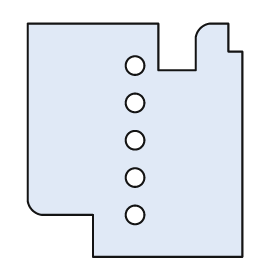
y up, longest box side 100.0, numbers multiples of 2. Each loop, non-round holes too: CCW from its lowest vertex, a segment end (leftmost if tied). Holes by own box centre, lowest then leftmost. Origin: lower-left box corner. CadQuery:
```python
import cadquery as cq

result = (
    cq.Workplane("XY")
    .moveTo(28.0, 0.0)
    .lineTo(92.0, 0.0)
    .lineTo(92.0, 88.0)
    .lineTo(86.0, 88.0)
    .lineTo(86.0, 100.0)
    .lineTo(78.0, 100.0)
    .threePointArc((74.0, 98.0), (72.0, 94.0))
    .lineTo(72.0, 80.0)
    .lineTo(56.0, 80.0)
    .lineTo(56.0, 100.0)
    .lineTo(0.0, 100.0)
    .lineTo(0.0, 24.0)
    .threePointArc((2.0, 20.0), (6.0, 18.0))
    .lineTo(28.0, 18.0)
    .close()
    .moveTo(46.0, 18.0)
    .circle(4.0)
    .moveTo(46.0, 34.0)
    .circle(4.0)
    .moveTo(46.0, 50.0)
    .circle(4.0)
    .moveTo(46.0, 66.0)
    .circle(4.0)
    .moveTo(46.0, 82.0)
    .circle(4.0)
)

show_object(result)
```